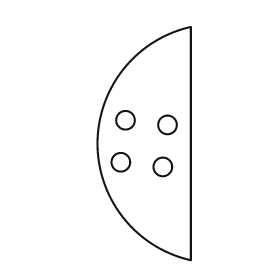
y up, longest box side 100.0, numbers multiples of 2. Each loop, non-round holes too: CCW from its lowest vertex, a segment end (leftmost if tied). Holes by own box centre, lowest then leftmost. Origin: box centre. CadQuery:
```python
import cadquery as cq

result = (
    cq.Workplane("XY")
    .moveTo(20.0, -50.0)
    .lineTo(20.0, 50.0)
    .threePointArc((-20.0, 0.0), (20.0, -50.0))
    .close()
    .moveTo(8.0, -10.0)
    .circle(4.0)
    .moveTo(-10.0, -8.0)
    .circle(4.0)
    .moveTo(10.0, 8.0)
    .circle(4.0)
    .moveTo(-8.0, 10.0)
    .circle(4.0)
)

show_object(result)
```